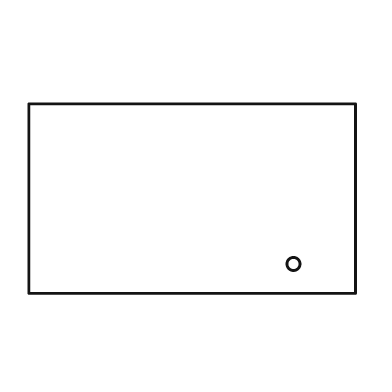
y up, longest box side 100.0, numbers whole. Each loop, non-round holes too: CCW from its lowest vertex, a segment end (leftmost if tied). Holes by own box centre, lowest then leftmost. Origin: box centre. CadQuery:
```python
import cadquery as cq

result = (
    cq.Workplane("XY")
    .moveTo(-50.0, -29.0)
    .lineTo(50.0, -29.0)
    .lineTo(50.0, 29.0)
    .lineTo(-50.0, 29.0)
    .close()
    .moveTo(31.0, -20.0)
    .circle(2.0)
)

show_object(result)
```